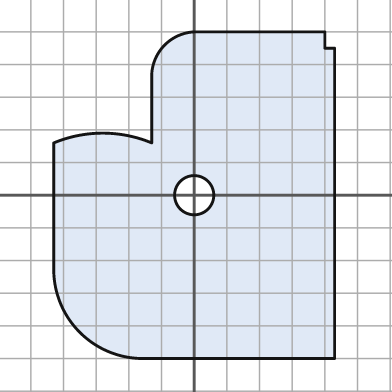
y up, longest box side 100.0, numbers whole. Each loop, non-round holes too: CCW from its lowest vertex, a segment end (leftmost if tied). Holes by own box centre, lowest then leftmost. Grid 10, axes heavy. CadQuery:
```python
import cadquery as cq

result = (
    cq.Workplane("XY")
    .moveTo(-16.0, -50.0)
    .lineTo(43.0, -50.0)
    .lineTo(43.0, 45.0)
    .lineTo(40.0, 45.0)
    .lineTo(40.0, 50.0)
    .lineTo(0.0, 50.0)
    .threePointArc((-9.0, 46.0), (-13.0, 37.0))
    .lineTo(-13.0, 16.0)
    .threePointArc((-28.0, 19.0), (-43.0, 16.0))
    .lineTo(-43.0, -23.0)
    .threePointArc((-35.0, -42.0), (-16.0, -50.0))
    .close()
    .moveTo(0.0, 0.0)
    .circle(6.0)
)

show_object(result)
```